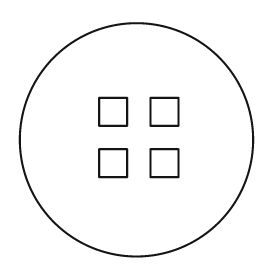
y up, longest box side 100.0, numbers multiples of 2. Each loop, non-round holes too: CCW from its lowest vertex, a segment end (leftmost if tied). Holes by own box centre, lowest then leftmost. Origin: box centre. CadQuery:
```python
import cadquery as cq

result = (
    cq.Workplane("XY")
    .moveTo(0.0, 0.0)
    .circle(50.0)
    .moveTo(-16.0, -16.0)
    .lineTo(-4.0, -16.0)
    .lineTo(-4.0, -4.0)
    .lineTo(-16.0, -4.0)
    .close()
    .moveTo(6.0, -16.0)
    .lineTo(18.0, -16.0)
    .lineTo(18.0, -4.0)
    .lineTo(6.0, -4.0)
    .close()
    .moveTo(-16.0, 6.0)
    .lineTo(-4.0, 6.0)
    .lineTo(-4.0, 18.0)
    .lineTo(-16.0, 18.0)
    .close()
    .moveTo(6.0, 6.0)
    .lineTo(18.0, 6.0)
    .lineTo(18.0, 18.0)
    .lineTo(6.0, 18.0)
    .close()
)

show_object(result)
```